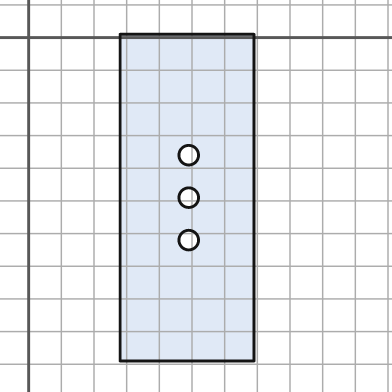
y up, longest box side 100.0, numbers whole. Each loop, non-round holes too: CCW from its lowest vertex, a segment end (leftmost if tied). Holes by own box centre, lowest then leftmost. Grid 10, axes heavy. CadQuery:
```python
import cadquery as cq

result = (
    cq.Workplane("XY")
    .moveTo(28.0, -99.0)
    .lineTo(69.0, -99.0)
    .lineTo(69.0, 1.0)
    .lineTo(28.0, 1.0)
    .close()
    .moveTo(49.0, -62.0)
    .circle(3.0)
    .moveTo(49.0, -49.0)
    .circle(3.0)
    .moveTo(49.0, -36.0)
    .circle(3.0)
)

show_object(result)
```